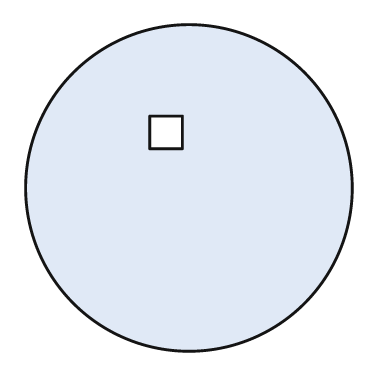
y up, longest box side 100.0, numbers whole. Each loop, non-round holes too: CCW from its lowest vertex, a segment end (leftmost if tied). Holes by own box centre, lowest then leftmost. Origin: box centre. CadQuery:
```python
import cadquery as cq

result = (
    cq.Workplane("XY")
    .moveTo(0.0, 0.0)
    .circle(50.0)
    .moveTo(-12.0, 12.0)
    .lineTo(-2.0, 12.0)
    .lineTo(-2.0, 22.0)
    .lineTo(-12.0, 22.0)
    .close()
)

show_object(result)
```